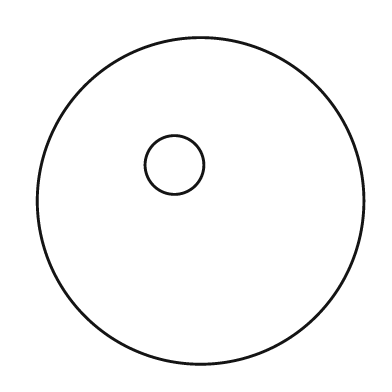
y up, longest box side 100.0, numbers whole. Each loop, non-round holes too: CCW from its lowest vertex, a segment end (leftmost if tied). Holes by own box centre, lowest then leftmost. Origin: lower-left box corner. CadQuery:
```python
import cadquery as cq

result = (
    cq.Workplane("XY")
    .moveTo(50.0, 50.0)
    .circle(50.0)
    .moveTo(42.0, 61.0)
    .circle(9.0)
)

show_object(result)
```